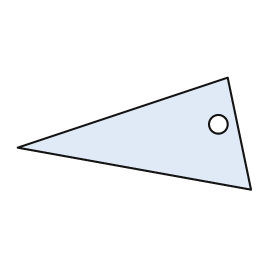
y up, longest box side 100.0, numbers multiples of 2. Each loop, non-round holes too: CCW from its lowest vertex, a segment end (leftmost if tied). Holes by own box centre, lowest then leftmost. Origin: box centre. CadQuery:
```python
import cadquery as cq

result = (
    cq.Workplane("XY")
    .moveTo(50.0, -24.0)
    .lineTo(40.0, 24.0)
    .lineTo(-50.0, -6.0)
    .close()
    .moveTo(36.0, 4.0)
    .circle(4.0)
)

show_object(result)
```